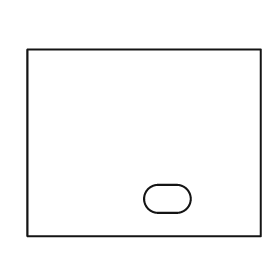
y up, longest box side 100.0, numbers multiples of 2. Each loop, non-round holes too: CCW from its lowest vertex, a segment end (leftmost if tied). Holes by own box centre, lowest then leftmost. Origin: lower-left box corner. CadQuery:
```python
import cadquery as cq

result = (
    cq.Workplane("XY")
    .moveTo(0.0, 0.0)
    .lineTo(100.0, 0.0)
    .lineTo(100.0, 80.0)
    .lineTo(0.0, 80.0)
    .close()
    .moveTo(56.0, 10.0)
    .lineTo(64.0, 10.0)
    .threePointArc((70.0, 16.0), (64.0, 22.0))
    .lineTo(56.0, 22.0)
    .threePointArc((50.0, 16.0), (56.0, 10.0))
    .close()
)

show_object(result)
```